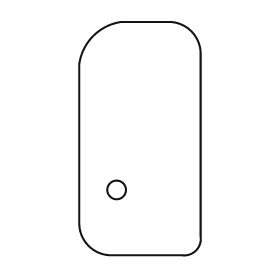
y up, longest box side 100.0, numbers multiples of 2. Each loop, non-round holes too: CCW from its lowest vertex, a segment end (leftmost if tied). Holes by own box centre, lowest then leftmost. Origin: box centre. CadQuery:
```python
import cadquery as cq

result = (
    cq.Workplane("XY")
    .moveTo(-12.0, -50.0)
    .lineTo(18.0, -50.0)
    .threePointArc((24.0, -48.0), (26.0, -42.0))
    .lineTo(26.0, 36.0)
    .threePointArc((22.0, 46.0), (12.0, 50.0))
    .lineTo(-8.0, 50.0)
    .threePointArc((-20.0, 44.0), (-26.0, 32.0))
    .lineTo(-26.0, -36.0)
    .threePointArc((-22.0, -46.0), (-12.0, -50.0))
    .close()
    .moveTo(-10.0, -22.0)
    .circle(4.0)
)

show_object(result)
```